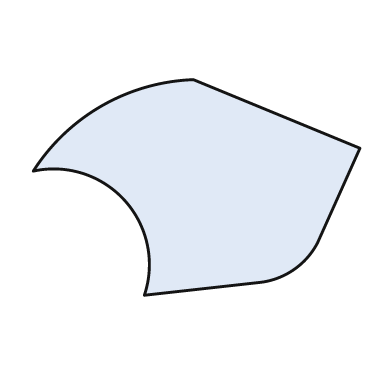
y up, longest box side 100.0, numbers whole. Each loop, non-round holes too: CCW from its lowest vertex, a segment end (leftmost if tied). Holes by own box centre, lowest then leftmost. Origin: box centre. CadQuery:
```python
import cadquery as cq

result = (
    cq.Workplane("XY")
    .moveTo(-16.0, -33.0)
    .lineTo(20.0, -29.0)
    .threePointArc((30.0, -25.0), (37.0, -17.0))
    .lineTo(50.0, 12.0)
    .lineTo(-1.0, 33.0)
    .threePointArc((-29.0, 25.0), (-50.0, 5.0))
    .threePointArc((-22.0, -4.0), (-16.0, -33.0))
    .close()
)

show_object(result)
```